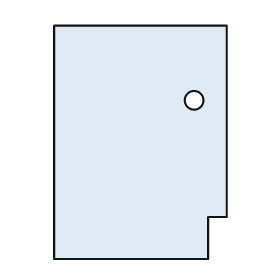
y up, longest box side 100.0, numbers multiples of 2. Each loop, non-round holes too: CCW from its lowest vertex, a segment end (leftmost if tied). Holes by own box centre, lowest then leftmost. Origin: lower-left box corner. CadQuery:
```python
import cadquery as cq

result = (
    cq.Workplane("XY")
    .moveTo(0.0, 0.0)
    .lineTo(66.0, 0.0)
    .lineTo(66.0, 18.0)
    .lineTo(74.0, 18.0)
    .lineTo(74.0, 100.0)
    .lineTo(0.0, 100.0)
    .close()
    .moveTo(60.0, 68.0)
    .circle(4.0)
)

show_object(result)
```